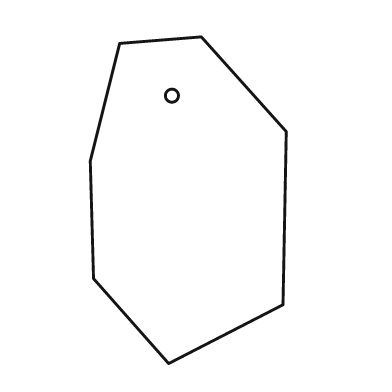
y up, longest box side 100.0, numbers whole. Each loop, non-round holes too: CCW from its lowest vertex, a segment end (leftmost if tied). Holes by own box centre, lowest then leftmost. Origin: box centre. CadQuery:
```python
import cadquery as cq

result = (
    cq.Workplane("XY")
    .moveTo(-6.0, -50.0)
    .lineTo(29.0, -32.0)
    .lineTo(30.0, 21.0)
    .lineTo(4.0, 50.0)
    .lineTo(-21.0, 48.0)
    .lineTo(-30.0, 12.0)
    .lineTo(-29.0, -24.0)
    .close()
    .moveTo(-5.0, 32.0)
    .circle(2.0)
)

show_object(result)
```